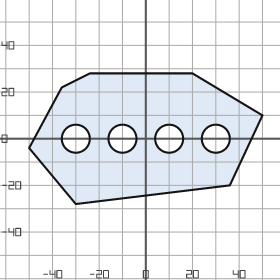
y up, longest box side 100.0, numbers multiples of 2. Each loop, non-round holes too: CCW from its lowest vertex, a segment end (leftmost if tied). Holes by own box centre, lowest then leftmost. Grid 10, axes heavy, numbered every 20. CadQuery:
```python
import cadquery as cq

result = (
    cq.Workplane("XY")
    .moveTo(-30.0, -28.0)
    .lineTo(36.0, -20.0)
    .lineTo(50.0, 10.0)
    .lineTo(20.0, 28.0)
    .lineTo(-24.0, 28.0)
    .lineTo(-36.0, 22.0)
    .lineTo(-50.0, -4.0)
    .close()
    .moveTo(-30.0, 0.0)
    .circle(6.0)
    .moveTo(-10.0, 0.0)
    .circle(6.0)
    .moveTo(10.0, 0.0)
    .circle(6.0)
    .moveTo(30.0, 0.0)
    .circle(6.0)
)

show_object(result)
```